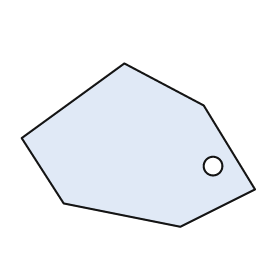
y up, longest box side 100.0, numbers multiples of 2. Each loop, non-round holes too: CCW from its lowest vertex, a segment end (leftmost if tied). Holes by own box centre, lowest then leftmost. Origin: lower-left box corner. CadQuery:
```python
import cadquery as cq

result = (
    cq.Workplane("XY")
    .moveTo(68.0, 0.0)
    .lineTo(100.0, 16.0)
    .lineTo(78.0, 52.0)
    .lineTo(44.0, 70.0)
    .lineTo(0.0, 38.0)
    .lineTo(18.0, 10.0)
    .close()
    .moveTo(82.0, 26.0)
    .circle(4.0)
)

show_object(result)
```